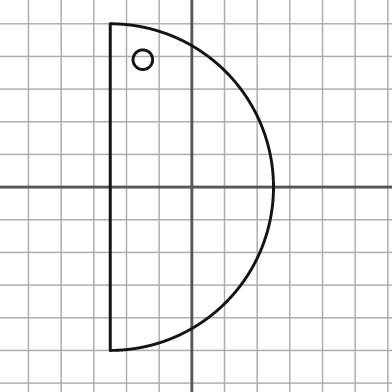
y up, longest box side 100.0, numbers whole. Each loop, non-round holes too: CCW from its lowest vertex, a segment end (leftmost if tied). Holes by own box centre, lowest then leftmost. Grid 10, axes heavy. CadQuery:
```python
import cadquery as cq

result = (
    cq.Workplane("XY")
    .moveTo(-25.0, -50.0)
    .threePointArc((25.0, 0.0), (-25.0, 50.0))
    .close()
    .moveTo(-15.0, 39.0)
    .circle(3.0)
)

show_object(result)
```